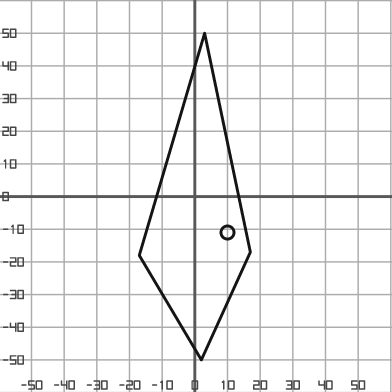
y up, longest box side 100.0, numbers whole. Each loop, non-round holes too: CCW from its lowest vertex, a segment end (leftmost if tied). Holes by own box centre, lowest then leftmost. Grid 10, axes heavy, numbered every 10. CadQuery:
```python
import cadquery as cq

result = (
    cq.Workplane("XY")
    .moveTo(2.0, -50.0)
    .lineTo(17.0, -17.0)
    .lineTo(3.0, 50.0)
    .lineTo(-17.0, -18.0)
    .close()
    .moveTo(10.0, -11.0)
    .circle(2.0)
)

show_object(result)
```